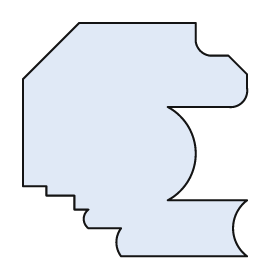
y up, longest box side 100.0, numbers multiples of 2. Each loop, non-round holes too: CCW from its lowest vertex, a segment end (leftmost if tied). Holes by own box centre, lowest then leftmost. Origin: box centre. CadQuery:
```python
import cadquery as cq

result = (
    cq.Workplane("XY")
    .moveTo(-6.0, -50.0)
    .lineTo(48.0, -50.0)
    .threePointArc((42.0, -38.0), (48.0, -26.0))
    .lineTo(14.0, -26.0)
    .threePointArc((26.0, -6.0), (14.0, 14.0))
    .lineTo(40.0, 14.0)
    .threePointArc((46.0, 16.0), (48.0, 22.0))
    .lineTo(48.0, 28.0)
    .lineTo(40.0, 36.0)
    .lineTo(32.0, 36.0)
    .threePointArc((28.0, 38.0), (26.0, 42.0))
    .lineTo(26.0, 50.0)
    .lineTo(-24.0, 50.0)
    .lineTo(-48.0, 26.0)
    .lineTo(-48.0, -20.0)
    .lineTo(-38.0, -20.0)
    .lineTo(-38.0, -24.0)
    .lineTo(-26.0, -24.0)
    .lineTo(-26.0, -30.0)
    .lineTo(-20.0, -30.0)
    .threePointArc((-22.0, -34.0), (-20.0, -38.0))
    .lineTo(-6.0, -38.0)
    .threePointArc((-8.0, -44.0), (-6.0, -50.0))
    .close()
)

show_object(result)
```